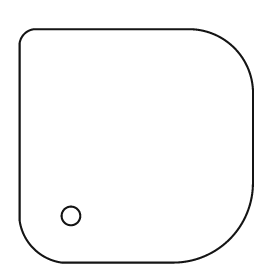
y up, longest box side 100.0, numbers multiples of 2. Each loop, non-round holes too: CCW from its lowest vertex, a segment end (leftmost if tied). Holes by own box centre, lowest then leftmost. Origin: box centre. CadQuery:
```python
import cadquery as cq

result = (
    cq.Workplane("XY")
    .moveTo(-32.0, -50.0)
    .lineTo(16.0, -50.0)
    .threePointArc((40.0, -40.0), (50.0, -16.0))
    .lineTo(50.0, 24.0)
    .threePointArc((42.0, 42.0), (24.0, 50.0))
    .lineTo(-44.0, 50.0)
    .threePointArc((-48.0, 48.0), (-50.0, 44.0))
    .lineTo(-50.0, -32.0)
    .threePointArc((-44.0, -44.0), (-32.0, -50.0))
    .close()
    .moveTo(-28.0, -30.0)
    .circle(4.0)
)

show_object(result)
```